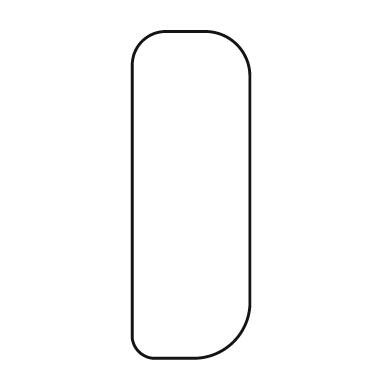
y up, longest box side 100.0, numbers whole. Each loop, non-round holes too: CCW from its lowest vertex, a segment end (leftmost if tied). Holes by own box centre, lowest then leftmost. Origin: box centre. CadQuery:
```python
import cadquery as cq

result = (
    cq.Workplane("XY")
    .moveTo(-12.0, -50.0)
    .lineTo(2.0, -50.0)
    .threePointArc((13.0, -45.0), (18.0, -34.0))
    .lineTo(18.0, 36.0)
    .threePointArc((14.0, 46.0), (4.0, 50.0))
    .lineTo(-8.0, 50.0)
    .threePointArc((-15.0, 47.0), (-18.0, 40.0))
    .lineTo(-18.0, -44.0)
    .threePointArc((-16.0, -48.0), (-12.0, -50.0))
    .close()
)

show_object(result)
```